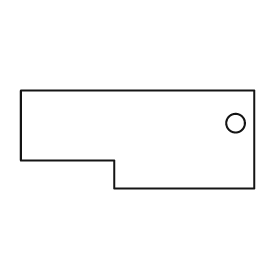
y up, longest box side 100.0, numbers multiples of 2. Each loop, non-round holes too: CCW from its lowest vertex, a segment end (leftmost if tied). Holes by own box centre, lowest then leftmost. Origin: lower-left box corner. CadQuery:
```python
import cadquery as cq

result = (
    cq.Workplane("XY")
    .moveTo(40.0, 0.0)
    .lineTo(100.0, 0.0)
    .lineTo(100.0, 42.0)
    .lineTo(0.0, 42.0)
    .lineTo(0.0, 12.0)
    .lineTo(40.0, 12.0)
    .close()
    .moveTo(92.0, 28.0)
    .circle(4.0)
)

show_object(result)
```